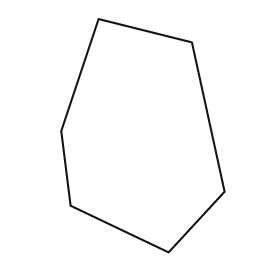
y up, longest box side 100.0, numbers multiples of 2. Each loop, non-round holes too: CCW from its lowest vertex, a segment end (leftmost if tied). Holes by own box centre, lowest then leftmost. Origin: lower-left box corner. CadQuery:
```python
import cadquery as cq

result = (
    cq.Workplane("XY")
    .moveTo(46.0, 0.0)
    .lineTo(70.0, 26.0)
    .lineTo(56.0, 90.0)
    .lineTo(16.0, 100.0)
    .lineTo(0.0, 52.0)
    .lineTo(4.0, 20.0)
    .close()
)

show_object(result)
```